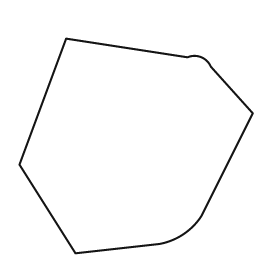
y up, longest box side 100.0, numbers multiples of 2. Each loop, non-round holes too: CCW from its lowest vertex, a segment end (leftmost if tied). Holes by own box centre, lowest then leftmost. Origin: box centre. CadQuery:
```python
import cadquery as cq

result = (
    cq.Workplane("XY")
    .moveTo(-26.0, -46.0)
    .lineTo(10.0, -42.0)
    .threePointArc((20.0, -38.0), (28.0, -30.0))
    .lineTo(50.0, 14.0)
    .lineTo(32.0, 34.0)
    .threePointArc((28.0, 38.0), (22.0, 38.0))
    .lineTo(-30.0, 46.0)
    .lineTo(-50.0, -8.0)
    .close()
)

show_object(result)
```